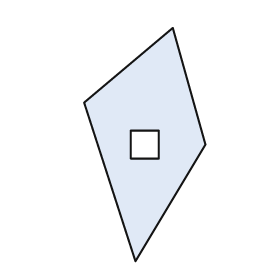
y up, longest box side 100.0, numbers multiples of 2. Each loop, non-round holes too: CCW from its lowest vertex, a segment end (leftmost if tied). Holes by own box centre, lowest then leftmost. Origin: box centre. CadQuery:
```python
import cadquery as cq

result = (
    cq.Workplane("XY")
    .moveTo(-4.0, -50.0)
    .lineTo(26.0, 0.0)
    .lineTo(12.0, 50.0)
    .lineTo(-26.0, 18.0)
    .close()
    .moveTo(-6.0, -6.0)
    .lineTo(6.0, -6.0)
    .lineTo(6.0, 6.0)
    .lineTo(-6.0, 6.0)
    .close()
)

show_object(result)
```